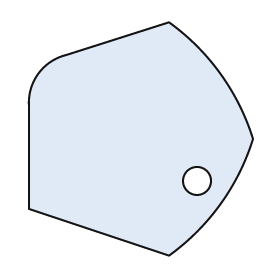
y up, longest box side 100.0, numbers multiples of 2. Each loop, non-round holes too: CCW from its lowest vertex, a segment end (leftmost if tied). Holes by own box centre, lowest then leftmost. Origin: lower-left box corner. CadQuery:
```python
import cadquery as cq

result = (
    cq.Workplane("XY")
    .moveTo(60.0, 0.0)
    .threePointArc((82.0, 22.0), (96.0, 50.0))
    .threePointArc((82.0, 78.0), (60.0, 100.0))
    .lineTo(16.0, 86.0)
    .threePointArc((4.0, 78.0), (0.0, 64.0))
    .lineTo(0.0, 20.0)
    .close()
    .moveTo(72.0, 32.0)
    .circle(6.0)
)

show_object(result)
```